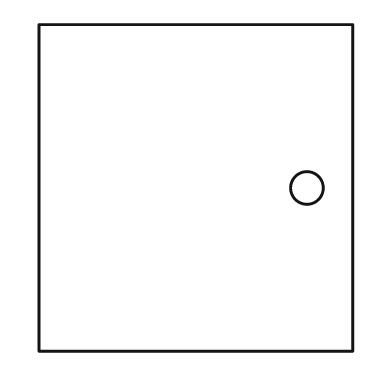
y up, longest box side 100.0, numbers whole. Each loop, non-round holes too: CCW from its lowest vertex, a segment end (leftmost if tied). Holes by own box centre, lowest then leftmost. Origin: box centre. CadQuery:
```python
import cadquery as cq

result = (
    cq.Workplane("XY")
    .moveTo(-48.0, -50.0)
    .lineTo(48.0, -50.0)
    .lineTo(48.0, 50.0)
    .lineTo(-48.0, 50.0)
    .close()
    .moveTo(34.0, 0.0)
    .circle(5.0)
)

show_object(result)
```